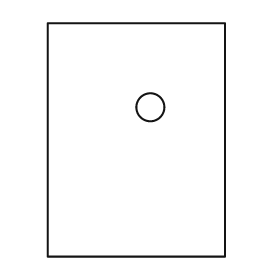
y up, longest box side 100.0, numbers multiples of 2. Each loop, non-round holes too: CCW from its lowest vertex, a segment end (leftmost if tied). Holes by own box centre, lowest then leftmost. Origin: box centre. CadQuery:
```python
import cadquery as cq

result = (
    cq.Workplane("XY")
    .moveTo(-38.0, -50.0)
    .lineTo(38.0, -50.0)
    .lineTo(38.0, 50.0)
    .lineTo(-38.0, 50.0)
    .close()
    .moveTo(6.0, 14.0)
    .circle(6.0)
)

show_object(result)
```